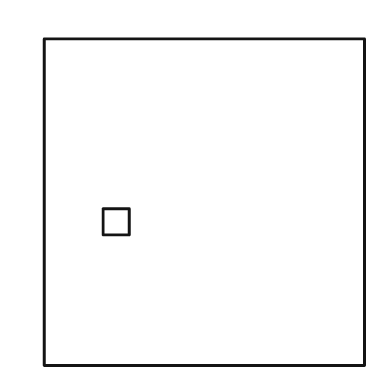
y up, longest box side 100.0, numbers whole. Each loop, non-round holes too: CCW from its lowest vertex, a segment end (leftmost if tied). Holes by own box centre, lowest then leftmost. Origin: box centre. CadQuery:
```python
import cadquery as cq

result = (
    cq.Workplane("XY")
    .moveTo(-49.0, -50.0)
    .lineTo(49.0, -50.0)
    .lineTo(49.0, 50.0)
    .lineTo(-49.0, 50.0)
    .close()
    .moveTo(-31.0, -10.0)
    .lineTo(-23.0, -10.0)
    .lineTo(-23.0, -2.0)
    .lineTo(-31.0, -2.0)
    .close()
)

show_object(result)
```